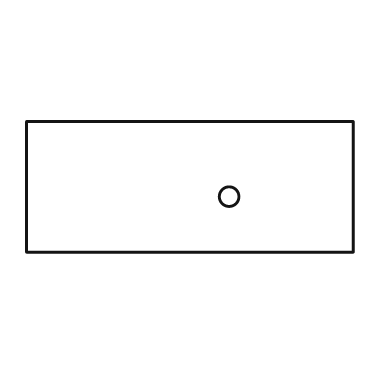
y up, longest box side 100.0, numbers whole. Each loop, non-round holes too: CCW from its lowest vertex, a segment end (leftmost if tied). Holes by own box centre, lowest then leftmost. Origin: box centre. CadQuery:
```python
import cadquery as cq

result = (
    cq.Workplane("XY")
    .moveTo(-50.0, -20.0)
    .lineTo(50.0, -20.0)
    .lineTo(50.0, 20.0)
    .lineTo(-50.0, 20.0)
    .close()
    .moveTo(12.0, -3.0)
    .circle(3.0)
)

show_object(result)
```